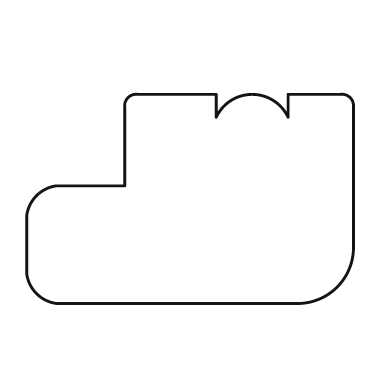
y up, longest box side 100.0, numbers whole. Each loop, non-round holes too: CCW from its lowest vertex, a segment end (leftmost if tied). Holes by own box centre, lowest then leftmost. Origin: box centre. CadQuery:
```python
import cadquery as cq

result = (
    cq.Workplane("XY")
    .moveTo(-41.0, -32.0)
    .lineTo(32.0, -32.0)
    .threePointArc((45.0, -27.0), (50.0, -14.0))
    .lineTo(50.0, 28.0)
    .threePointArc((49.0, 31.0), (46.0, 32.0))
    .lineTo(30.0, 32.0)
    .lineTo(30.0, 25.0)
    .threePointArc((19.0, 32.0), (8.0, 25.0))
    .lineTo(8.0, 32.0)
    .lineTo(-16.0, 32.0)
    .threePointArc((-19.0, 31.0), (-20.0, 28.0))
    .lineTo(-20.0, 4.0)
    .lineTo(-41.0, 4.0)
    .threePointArc((-47.0, 1.0), (-50.0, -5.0))
    .lineTo(-50.0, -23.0)
    .threePointArc((-47.0, -29.0), (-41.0, -32.0))
    .close()
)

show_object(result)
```